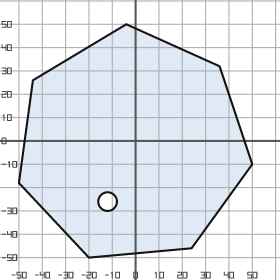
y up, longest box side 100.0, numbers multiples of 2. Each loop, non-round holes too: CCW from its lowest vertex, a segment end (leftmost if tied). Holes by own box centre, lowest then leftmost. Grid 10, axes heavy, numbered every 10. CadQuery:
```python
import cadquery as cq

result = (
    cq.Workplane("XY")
    .moveTo(-20.0, -50.0)
    .lineTo(24.0, -46.0)
    .lineTo(50.0, -10.0)
    .lineTo(36.0, 32.0)
    .lineTo(-4.0, 50.0)
    .lineTo(-44.0, 26.0)
    .lineTo(-50.0, -18.0)
    .close()
    .moveTo(-12.0, -26.0)
    .circle(4.0)
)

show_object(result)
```